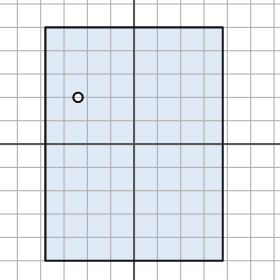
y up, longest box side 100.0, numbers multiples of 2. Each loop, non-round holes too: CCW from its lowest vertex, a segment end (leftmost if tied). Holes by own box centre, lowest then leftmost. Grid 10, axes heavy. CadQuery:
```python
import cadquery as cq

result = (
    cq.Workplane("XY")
    .moveTo(-38.0, -50.0)
    .lineTo(38.0, -50.0)
    .lineTo(38.0, 50.0)
    .lineTo(-38.0, 50.0)
    .close()
    .moveTo(-24.0, 20.0)
    .circle(2.0)
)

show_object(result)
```